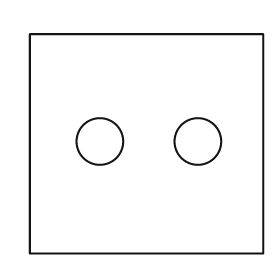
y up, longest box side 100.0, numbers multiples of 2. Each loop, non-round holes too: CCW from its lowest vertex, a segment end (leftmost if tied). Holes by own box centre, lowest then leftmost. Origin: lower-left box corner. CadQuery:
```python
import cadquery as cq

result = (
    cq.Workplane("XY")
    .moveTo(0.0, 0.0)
    .lineTo(100.0, 0.0)
    .lineTo(100.0, 94.0)
    .lineTo(0.0, 94.0)
    .close()
    .moveTo(30.0, 48.0)
    .circle(10.0)
    .moveTo(72.0, 48.0)
    .circle(10.0)
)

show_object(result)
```